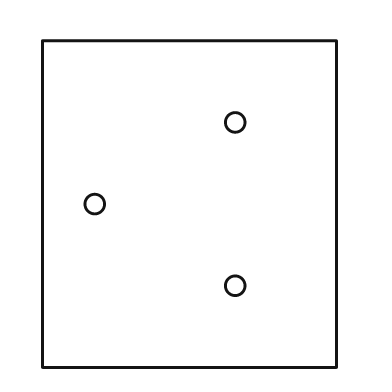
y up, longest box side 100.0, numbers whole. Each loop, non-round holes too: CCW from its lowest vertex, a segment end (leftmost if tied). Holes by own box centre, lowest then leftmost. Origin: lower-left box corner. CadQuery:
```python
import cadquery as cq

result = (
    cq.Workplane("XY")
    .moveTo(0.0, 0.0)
    .lineTo(90.0, 0.0)
    .lineTo(90.0, 100.0)
    .lineTo(0.0, 100.0)
    .close()
    .moveTo(59.0, 25.0)
    .circle(3.0)
    .moveTo(16.0, 50.0)
    .circle(3.0)
    .moveTo(59.0, 75.0)
    .circle(3.0)
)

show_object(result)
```